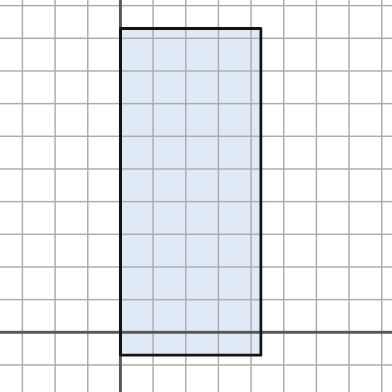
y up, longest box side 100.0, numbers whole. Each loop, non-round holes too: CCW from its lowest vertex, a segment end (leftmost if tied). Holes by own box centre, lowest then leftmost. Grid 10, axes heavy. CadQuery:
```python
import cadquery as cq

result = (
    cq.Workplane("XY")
    .moveTo(0.0, -7.0)
    .lineTo(43.0, -7.0)
    .lineTo(43.0, 93.0)
    .lineTo(0.0, 93.0)
    .close()
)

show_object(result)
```